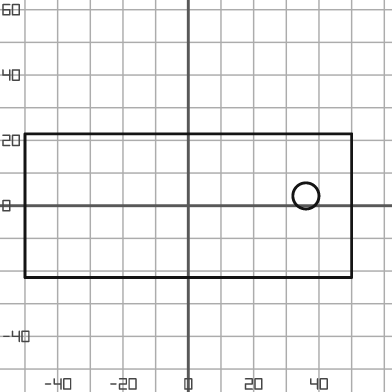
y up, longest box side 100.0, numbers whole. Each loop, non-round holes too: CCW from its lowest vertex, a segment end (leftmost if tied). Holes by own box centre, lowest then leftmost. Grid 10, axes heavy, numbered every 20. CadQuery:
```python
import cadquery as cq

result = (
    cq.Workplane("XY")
    .moveTo(-50.0, -22.0)
    .lineTo(50.0, -22.0)
    .lineTo(50.0, 22.0)
    .lineTo(-50.0, 22.0)
    .close()
    .moveTo(36.0, 3.0)
    .circle(4.0)
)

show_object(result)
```